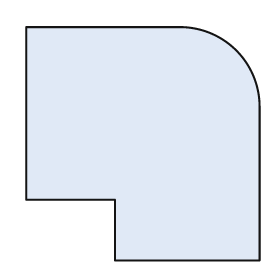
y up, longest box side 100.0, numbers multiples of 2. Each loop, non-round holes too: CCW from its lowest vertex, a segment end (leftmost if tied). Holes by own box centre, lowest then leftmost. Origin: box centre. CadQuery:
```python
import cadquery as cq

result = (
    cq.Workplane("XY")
    .moveTo(-12.0, -50.0)
    .lineTo(50.0, -50.0)
    .lineTo(50.0, 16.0)
    .threePointArc((40.0, 40.0), (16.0, 50.0))
    .lineTo(-50.0, 50.0)
    .lineTo(-50.0, -24.0)
    .lineTo(-12.0, -24.0)
    .close()
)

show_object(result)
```